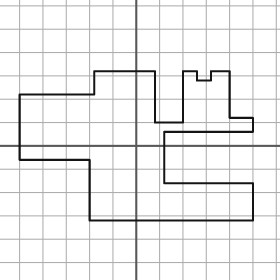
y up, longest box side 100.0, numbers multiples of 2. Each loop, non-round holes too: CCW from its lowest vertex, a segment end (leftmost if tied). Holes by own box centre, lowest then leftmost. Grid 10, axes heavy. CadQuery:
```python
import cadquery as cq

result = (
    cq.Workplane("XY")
    .moveTo(-20.0, -32.0)
    .lineTo(50.0, -32.0)
    .lineTo(50.0, -16.0)
    .lineTo(12.0, -16.0)
    .lineTo(12.0, 6.0)
    .lineTo(50.0, 6.0)
    .lineTo(50.0, 12.0)
    .lineTo(40.0, 12.0)
    .lineTo(40.0, 32.0)
    .lineTo(32.0, 32.0)
    .lineTo(32.0, 28.0)
    .lineTo(26.0, 28.0)
    .lineTo(26.0, 32.0)
    .lineTo(20.0, 32.0)
    .lineTo(20.0, 10.0)
    .lineTo(8.0, 10.0)
    .lineTo(8.0, 32.0)
    .lineTo(-18.0, 32.0)
    .lineTo(-18.0, 22.0)
    .lineTo(-50.0, 22.0)
    .lineTo(-50.0, -6.0)
    .lineTo(-20.0, -6.0)
    .close()
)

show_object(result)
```